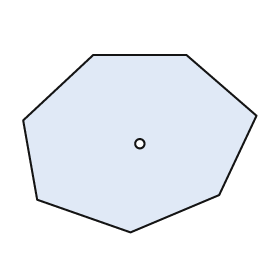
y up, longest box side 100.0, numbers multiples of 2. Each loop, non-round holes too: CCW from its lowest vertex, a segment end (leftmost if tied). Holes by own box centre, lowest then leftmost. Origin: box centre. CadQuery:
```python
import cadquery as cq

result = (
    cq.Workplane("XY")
    .moveTo(-4.0, -38.0)
    .lineTo(34.0, -22.0)
    .lineTo(50.0, 12.0)
    .lineTo(20.0, 38.0)
    .lineTo(-20.0, 38.0)
    .lineTo(-50.0, 10.0)
    .lineTo(-44.0, -24.0)
    .close()
    .moveTo(0.0, 0.0)
    .circle(2.0)
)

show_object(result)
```